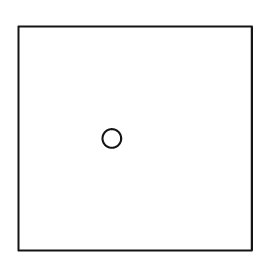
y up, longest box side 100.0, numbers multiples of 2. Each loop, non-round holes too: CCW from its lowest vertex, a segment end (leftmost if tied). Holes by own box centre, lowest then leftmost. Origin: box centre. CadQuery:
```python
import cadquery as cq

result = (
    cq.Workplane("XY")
    .moveTo(-50.0, -48.0)
    .lineTo(50.0, -48.0)
    .lineTo(50.0, 48.0)
    .lineTo(-50.0, 48.0)
    .close()
    .moveTo(-10.0, 0.0)
    .circle(4.0)
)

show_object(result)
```